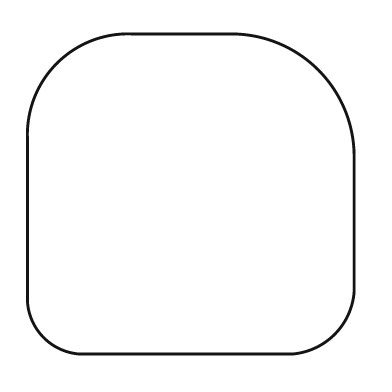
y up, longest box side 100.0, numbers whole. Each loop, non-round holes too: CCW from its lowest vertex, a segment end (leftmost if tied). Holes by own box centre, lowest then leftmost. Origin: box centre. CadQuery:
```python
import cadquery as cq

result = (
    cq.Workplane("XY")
    .moveTo(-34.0, -49.0)
    .lineTo(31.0, -49.0)
    .threePointArc((44.0, -43.0), (50.0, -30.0))
    .lineTo(50.0, 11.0)
    .threePointArc((39.0, 38.0), (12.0, 49.0))
    .lineTo(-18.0, 49.0)
    .threePointArc((-41.0, 40.0), (-50.0, 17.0))
    .lineTo(-50.0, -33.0)
    .threePointArc((-45.0, -44.0), (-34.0, -49.0))
    .close()
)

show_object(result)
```